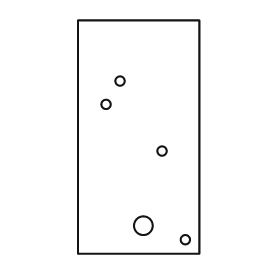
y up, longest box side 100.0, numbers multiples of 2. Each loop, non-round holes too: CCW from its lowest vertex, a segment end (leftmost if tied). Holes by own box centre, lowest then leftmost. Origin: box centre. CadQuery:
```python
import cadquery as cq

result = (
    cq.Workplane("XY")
    .moveTo(-26.0, -50.0)
    .lineTo(26.0, -50.0)
    .lineTo(26.0, 50.0)
    .lineTo(-26.0, 50.0)
    .close()
    .moveTo(20.0, -44.0)
    .circle(2.0)
    .moveTo(2.0, -38.0)
    .circle(4.0)
    .moveTo(10.0, -6.0)
    .circle(2.0)
    .moveTo(-14.0, 14.0)
    .circle(2.0)
    .moveTo(-8.0, 24.0)
    .circle(2.0)
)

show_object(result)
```